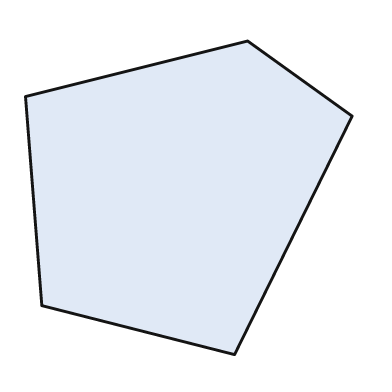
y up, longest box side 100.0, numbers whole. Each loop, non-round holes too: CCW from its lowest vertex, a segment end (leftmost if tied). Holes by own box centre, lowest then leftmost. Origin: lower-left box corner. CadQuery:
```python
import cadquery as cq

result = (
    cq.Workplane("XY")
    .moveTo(64.0, 0.0)
    .lineTo(100.0, 73.0)
    .lineTo(68.0, 96.0)
    .lineTo(0.0, 79.0)
    .lineTo(5.0, 15.0)
    .close()
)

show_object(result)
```